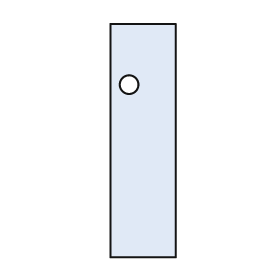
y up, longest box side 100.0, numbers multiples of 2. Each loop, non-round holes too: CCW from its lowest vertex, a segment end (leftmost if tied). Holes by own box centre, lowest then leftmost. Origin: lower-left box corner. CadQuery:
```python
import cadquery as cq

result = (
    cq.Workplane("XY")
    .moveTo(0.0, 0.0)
    .lineTo(28.0, 0.0)
    .lineTo(28.0, 100.0)
    .lineTo(0.0, 100.0)
    .close()
    .moveTo(8.0, 74.0)
    .circle(4.0)
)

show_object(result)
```